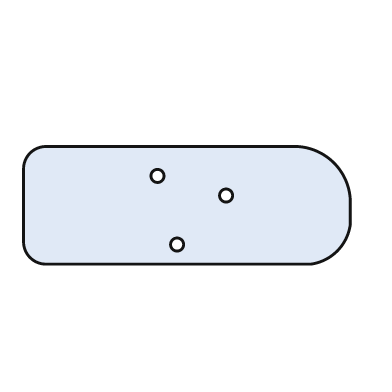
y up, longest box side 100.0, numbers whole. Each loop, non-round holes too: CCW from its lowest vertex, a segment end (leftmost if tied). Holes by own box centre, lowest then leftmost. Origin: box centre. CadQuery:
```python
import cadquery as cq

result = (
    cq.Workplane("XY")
    .moveTo(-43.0, -18.0)
    .lineTo(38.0, -18.0)
    .threePointArc((46.0, -14.0), (50.0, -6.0))
    .lineTo(50.0, 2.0)
    .threePointArc((45.0, 13.0), (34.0, 18.0))
    .lineTo(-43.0, 18.0)
    .threePointArc((-48.0, 16.0), (-50.0, 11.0))
    .lineTo(-50.0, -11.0)
    .threePointArc((-48.0, -16.0), (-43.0, -18.0))
    .close()
    .moveTo(-3.0, -12.0)
    .circle(2.0)
    .moveTo(12.0, 3.0)
    .circle(2.0)
    .moveTo(-9.0, 9.0)
    .circle(2.0)
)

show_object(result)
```